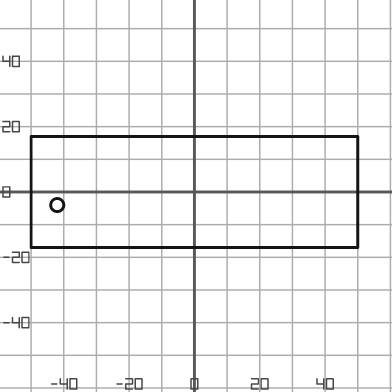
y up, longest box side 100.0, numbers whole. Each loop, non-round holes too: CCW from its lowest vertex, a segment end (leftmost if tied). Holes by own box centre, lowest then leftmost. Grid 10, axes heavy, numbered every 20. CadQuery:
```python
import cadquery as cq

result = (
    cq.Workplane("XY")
    .moveTo(-50.0, -17.0)
    .lineTo(50.0, -17.0)
    .lineTo(50.0, 17.0)
    .lineTo(-50.0, 17.0)
    .close()
    .moveTo(-42.0, -4.0)
    .circle(2.0)
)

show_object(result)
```